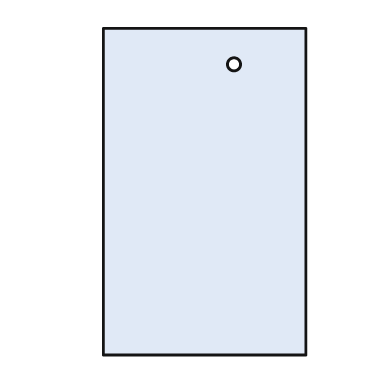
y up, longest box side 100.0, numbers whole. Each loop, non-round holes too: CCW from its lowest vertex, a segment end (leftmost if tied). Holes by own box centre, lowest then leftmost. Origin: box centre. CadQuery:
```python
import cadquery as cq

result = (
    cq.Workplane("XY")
    .moveTo(-31.0, -50.0)
    .lineTo(31.0, -50.0)
    .lineTo(31.0, 50.0)
    .lineTo(-31.0, 50.0)
    .close()
    .moveTo(9.0, 39.0)
    .circle(2.0)
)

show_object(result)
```